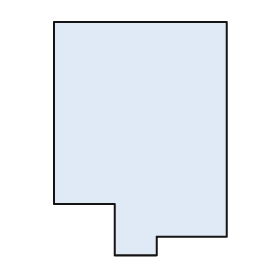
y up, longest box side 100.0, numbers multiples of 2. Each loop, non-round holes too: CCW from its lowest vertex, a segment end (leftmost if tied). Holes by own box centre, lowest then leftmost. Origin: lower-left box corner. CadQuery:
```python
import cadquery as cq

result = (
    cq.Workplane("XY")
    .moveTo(26.0, 0.0)
    .lineTo(44.0, 0.0)
    .lineTo(44.0, 8.0)
    .lineTo(74.0, 8.0)
    .lineTo(74.0, 100.0)
    .lineTo(0.0, 100.0)
    .lineTo(0.0, 22.0)
    .lineTo(26.0, 22.0)
    .close()
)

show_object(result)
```